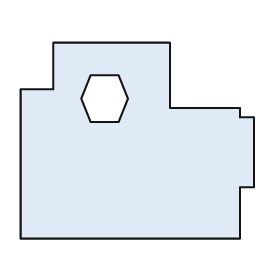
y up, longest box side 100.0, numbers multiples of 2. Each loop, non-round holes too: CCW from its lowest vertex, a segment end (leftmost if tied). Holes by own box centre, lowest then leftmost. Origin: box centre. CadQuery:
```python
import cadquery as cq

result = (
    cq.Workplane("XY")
    .moveTo(-50.0, -42.0)
    .lineTo(44.0, -42.0)
    .lineTo(44.0, -20.0)
    .lineTo(50.0, -20.0)
    .lineTo(50.0, 10.0)
    .lineTo(44.0, 10.0)
    .lineTo(44.0, 14.0)
    .lineTo(14.0, 14.0)
    .lineTo(14.0, 42.0)
    .lineTo(-36.0, 42.0)
    .lineTo(-36.0, 22.0)
    .lineTo(-50.0, 22.0)
    .close()
    .moveTo(-20.0, 8.0)
    .lineTo(-8.0, 8.0)
    .lineTo(-4.0, 18.0)
    .lineTo(-8.0, 28.0)
    .lineTo(-20.0, 28.0)
    .lineTo(-24.0, 18.0)
    .close()
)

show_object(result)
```